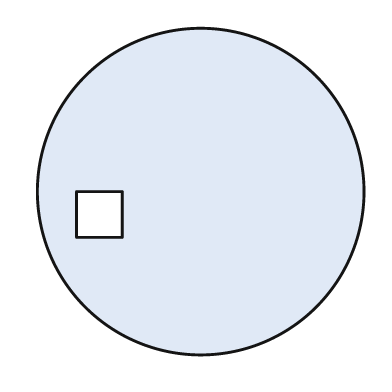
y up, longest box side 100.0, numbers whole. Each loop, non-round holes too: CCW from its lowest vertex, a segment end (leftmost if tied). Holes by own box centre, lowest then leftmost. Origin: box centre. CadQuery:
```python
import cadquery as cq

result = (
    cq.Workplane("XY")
    .moveTo(0.0, 0.0)
    .circle(50.0)
    .moveTo(-38.0, -14.0)
    .lineTo(-24.0, -14.0)
    .lineTo(-24.0, 0.0)
    .lineTo(-38.0, 0.0)
    .close()
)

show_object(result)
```